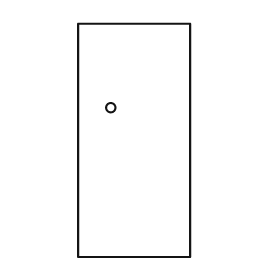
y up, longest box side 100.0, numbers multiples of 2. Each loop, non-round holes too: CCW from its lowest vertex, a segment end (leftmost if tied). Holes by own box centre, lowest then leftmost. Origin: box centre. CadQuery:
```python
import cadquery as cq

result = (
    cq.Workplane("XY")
    .moveTo(-24.0, -50.0)
    .lineTo(24.0, -50.0)
    .lineTo(24.0, 50.0)
    .lineTo(-24.0, 50.0)
    .close()
    .moveTo(-10.0, 14.0)
    .circle(2.0)
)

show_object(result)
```